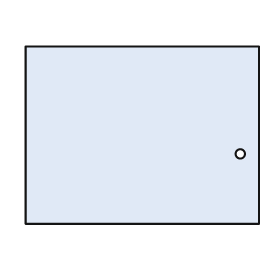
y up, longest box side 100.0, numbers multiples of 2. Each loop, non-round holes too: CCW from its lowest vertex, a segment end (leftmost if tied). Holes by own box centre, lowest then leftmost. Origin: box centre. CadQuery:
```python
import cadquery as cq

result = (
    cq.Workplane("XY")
    .moveTo(-50.0, -38.0)
    .lineTo(50.0, -38.0)
    .lineTo(50.0, 38.0)
    .lineTo(-50.0, 38.0)
    .close()
    .moveTo(42.0, -8.0)
    .circle(2.0)
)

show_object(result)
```